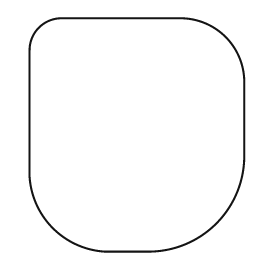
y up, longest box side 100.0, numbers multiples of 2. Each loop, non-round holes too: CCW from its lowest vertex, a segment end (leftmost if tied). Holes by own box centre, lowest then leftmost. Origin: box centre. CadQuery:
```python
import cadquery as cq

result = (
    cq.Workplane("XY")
    .moveTo(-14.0, -50.0)
    .lineTo(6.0, -50.0)
    .threePointArc((34.0, -38.0), (46.0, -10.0))
    .lineTo(46.0, 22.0)
    .threePointArc((38.0, 42.0), (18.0, 50.0))
    .lineTo(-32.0, 50.0)
    .threePointArc((-42.0, 46.0), (-46.0, 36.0))
    .lineTo(-46.0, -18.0)
    .threePointArc((-36.0, -40.0), (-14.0, -50.0))
    .close()
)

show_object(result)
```